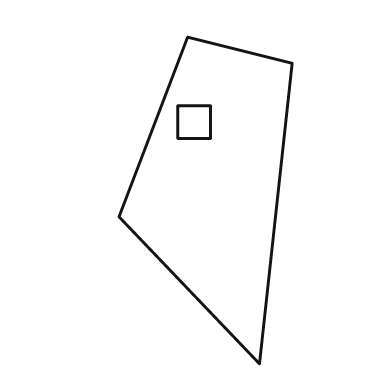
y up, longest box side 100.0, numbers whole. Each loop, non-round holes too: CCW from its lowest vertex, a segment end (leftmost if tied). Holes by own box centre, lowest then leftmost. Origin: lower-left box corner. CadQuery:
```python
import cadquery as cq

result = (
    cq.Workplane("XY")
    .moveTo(43.0, 0.0)
    .lineTo(53.0, 92.0)
    .lineTo(21.0, 100.0)
    .lineTo(0.0, 45.0)
    .close()
    .moveTo(18.0, 69.0)
    .lineTo(28.0, 69.0)
    .lineTo(28.0, 79.0)
    .lineTo(18.0, 79.0)
    .close()
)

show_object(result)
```